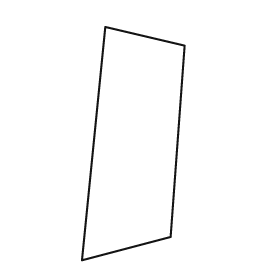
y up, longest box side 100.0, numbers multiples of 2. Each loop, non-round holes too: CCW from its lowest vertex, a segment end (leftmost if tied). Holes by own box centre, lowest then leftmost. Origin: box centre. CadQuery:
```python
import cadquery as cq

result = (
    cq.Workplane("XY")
    .moveTo(-22.0, -50.0)
    .lineTo(16.0, -40.0)
    .lineTo(22.0, 42.0)
    .lineTo(-12.0, 50.0)
    .close()
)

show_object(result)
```